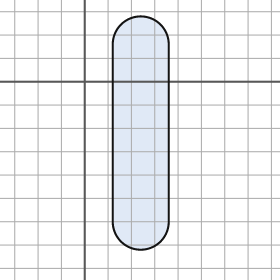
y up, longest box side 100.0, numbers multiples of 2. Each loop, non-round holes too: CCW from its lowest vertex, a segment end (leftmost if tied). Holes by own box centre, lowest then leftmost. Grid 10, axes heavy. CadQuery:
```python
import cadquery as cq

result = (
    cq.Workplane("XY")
    .moveTo(12.0, -60.0)
    .threePointArc((24.0, -72.0), (36.0, -60.0))
    .lineTo(36.0, 16.0)
    .threePointArc((24.0, 28.0), (12.0, 16.0))
    .close()
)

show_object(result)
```